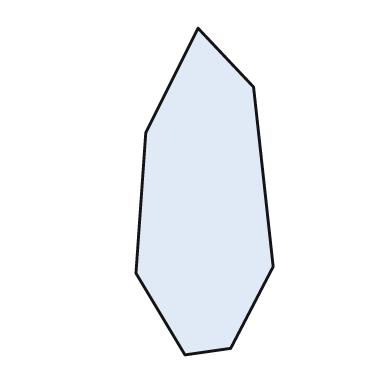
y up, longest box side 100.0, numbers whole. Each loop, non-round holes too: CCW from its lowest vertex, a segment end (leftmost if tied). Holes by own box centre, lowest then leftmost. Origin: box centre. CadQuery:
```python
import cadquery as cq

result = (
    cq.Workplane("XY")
    .moveTo(-6.0, -50.0)
    .lineTo(8.0, -48.0)
    .lineTo(21.0, -23.0)
    .lineTo(15.0, 32.0)
    .lineTo(-2.0, 50.0)
    .lineTo(-18.0, 18.0)
    .lineTo(-21.0, -25.0)
    .close()
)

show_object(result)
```